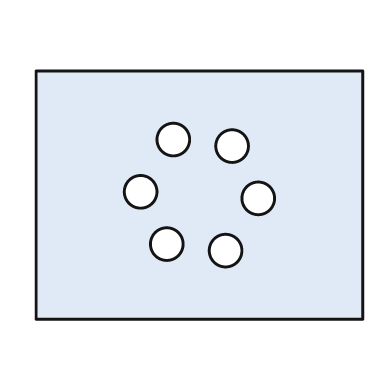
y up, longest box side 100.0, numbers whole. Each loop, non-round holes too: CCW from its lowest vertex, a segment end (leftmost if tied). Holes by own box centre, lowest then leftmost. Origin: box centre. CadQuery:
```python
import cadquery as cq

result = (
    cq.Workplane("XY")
    .moveTo(-50.0, -38.0)
    .lineTo(50.0, -38.0)
    .lineTo(50.0, 38.0)
    .lineTo(-50.0, 38.0)
    .close()
    .moveTo(8.0, -17.0)
    .circle(5.0)
    .moveTo(-10.0, -15.0)
    .circle(5.0)
    .moveTo(18.0, -1.0)
    .circle(5.0)
    .moveTo(-18.0, 1.0)
    .circle(5.0)
    .moveTo(10.0, 15.0)
    .circle(5.0)
    .moveTo(-8.0, 17.0)
    .circle(5.0)
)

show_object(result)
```